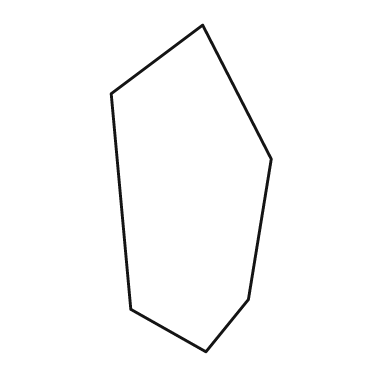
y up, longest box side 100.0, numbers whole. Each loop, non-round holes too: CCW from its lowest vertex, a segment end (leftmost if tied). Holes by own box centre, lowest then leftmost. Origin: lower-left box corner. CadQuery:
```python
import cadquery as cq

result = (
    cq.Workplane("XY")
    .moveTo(29.0, 0.0)
    .lineTo(42.0, 16.0)
    .lineTo(49.0, 59.0)
    .lineTo(28.0, 100.0)
    .lineTo(0.0, 79.0)
    .lineTo(6.0, 13.0)
    .close()
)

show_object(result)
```